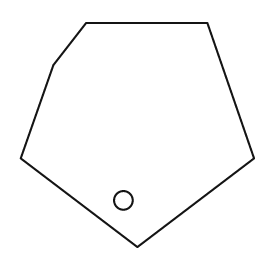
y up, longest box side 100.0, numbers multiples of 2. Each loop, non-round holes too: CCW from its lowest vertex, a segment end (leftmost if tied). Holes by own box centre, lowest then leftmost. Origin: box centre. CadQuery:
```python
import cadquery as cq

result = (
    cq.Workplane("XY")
    .moveTo(0.0, -48.0)
    .lineTo(50.0, -10.0)
    .lineTo(30.0, 48.0)
    .lineTo(-22.0, 48.0)
    .lineTo(-36.0, 30.0)
    .lineTo(-50.0, -10.0)
    .close()
    .moveTo(-6.0, -28.0)
    .circle(4.0)
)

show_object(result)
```